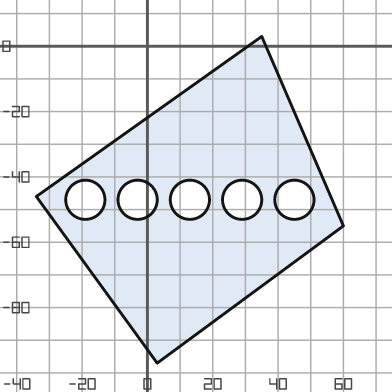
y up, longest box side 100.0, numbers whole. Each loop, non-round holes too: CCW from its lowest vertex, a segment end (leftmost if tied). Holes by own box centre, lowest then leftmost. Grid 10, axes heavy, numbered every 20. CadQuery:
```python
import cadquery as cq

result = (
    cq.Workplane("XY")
    .moveTo(3.0, -97.0)
    .lineTo(60.0, -55.0)
    .lineTo(35.0, 3.0)
    .lineTo(-34.0, -46.0)
    .close()
    .moveTo(-19.0, -47.0)
    .circle(6.0)
    .moveTo(-3.0, -47.0)
    .circle(6.0)
    .moveTo(13.0, -47.0)
    .circle(6.0)
    .moveTo(29.0, -47.0)
    .circle(6.0)
    .moveTo(45.0, -47.0)
    .circle(6.0)
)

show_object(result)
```